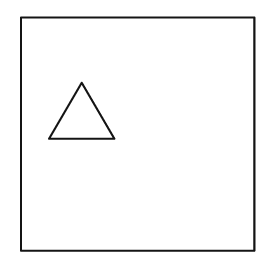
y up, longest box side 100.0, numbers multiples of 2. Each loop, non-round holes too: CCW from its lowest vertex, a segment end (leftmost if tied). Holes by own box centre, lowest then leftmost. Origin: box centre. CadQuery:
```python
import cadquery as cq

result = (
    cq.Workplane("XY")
    .moveTo(-50.0, -50.0)
    .lineTo(50.0, -50.0)
    .lineTo(50.0, 50.0)
    .lineTo(-50.0, 50.0)
    .close()
    .moveTo(-38.0, -2.0)
    .lineTo(-10.0, -2.0)
    .lineTo(-24.0, 22.0)
    .close()
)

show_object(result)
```